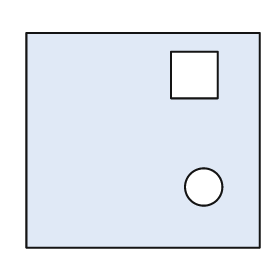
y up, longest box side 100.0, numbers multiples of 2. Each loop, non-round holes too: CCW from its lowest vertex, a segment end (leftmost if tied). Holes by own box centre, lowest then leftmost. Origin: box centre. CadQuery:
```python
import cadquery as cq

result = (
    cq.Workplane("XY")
    .moveTo(-50.0, -46.0)
    .lineTo(50.0, -46.0)
    .lineTo(50.0, 46.0)
    .lineTo(-50.0, 46.0)
    .close()
    .moveTo(26.0, -20.0)
    .circle(8.0)
    .moveTo(12.0, 18.0)
    .lineTo(32.0, 18.0)
    .lineTo(32.0, 38.0)
    .lineTo(12.0, 38.0)
    .close()
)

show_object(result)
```